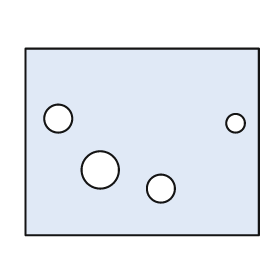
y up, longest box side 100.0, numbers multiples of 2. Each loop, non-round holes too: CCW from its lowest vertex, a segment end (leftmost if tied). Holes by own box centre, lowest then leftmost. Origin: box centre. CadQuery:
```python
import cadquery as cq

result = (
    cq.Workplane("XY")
    .moveTo(-50.0, -40.0)
    .lineTo(50.0, -40.0)
    .lineTo(50.0, 40.0)
    .lineTo(-50.0, 40.0)
    .close()
    .moveTo(8.0, -20.0)
    .circle(6.0)
    .moveTo(-18.0, -12.0)
    .circle(8.0)
    .moveTo(40.0, 8.0)
    .circle(4.0)
    .moveTo(-36.0, 10.0)
    .circle(6.0)
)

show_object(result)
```